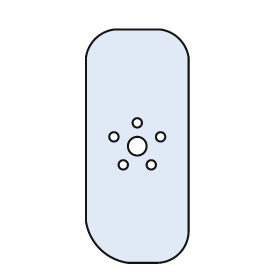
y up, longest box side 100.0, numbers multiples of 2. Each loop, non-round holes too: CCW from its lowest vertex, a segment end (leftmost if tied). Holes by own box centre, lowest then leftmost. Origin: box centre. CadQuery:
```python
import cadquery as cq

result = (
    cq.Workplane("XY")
    .moveTo(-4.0, -50.0)
    .lineTo(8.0, -50.0)
    .threePointArc((18.0, -46.0), (22.0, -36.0))
    .lineTo(22.0, 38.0)
    .threePointArc((18.0, 46.0), (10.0, 50.0))
    .lineTo(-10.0, 50.0)
    .threePointArc((-18.0, 46.0), (-22.0, 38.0))
    .lineTo(-22.0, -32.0)
    .threePointArc((-16.0, -44.0), (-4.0, -50.0))
    .close()
    .moveTo(-6.0, -8.0)
    .circle(2.0)
    .moveTo(6.0, -8.0)
    .circle(2.0)
    .moveTo(0.0, 0.0)
    .circle(4.0)
    .moveTo(-10.0, 4.0)
    .circle(2.0)
    .moveTo(10.0, 4.0)
    .circle(2.0)
    .moveTo(0.0, 10.0)
    .circle(2.0)
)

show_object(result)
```